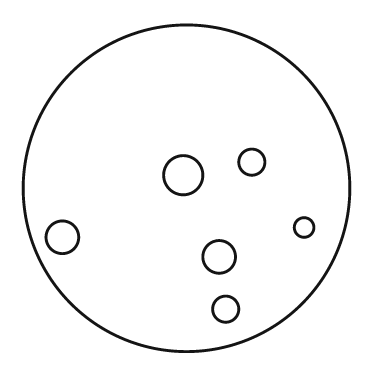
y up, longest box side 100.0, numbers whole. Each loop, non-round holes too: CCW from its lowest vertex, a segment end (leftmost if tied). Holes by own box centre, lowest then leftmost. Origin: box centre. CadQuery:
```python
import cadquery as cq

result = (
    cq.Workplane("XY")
    .moveTo(0.0, 0.0)
    .circle(50.0)
    .moveTo(12.0, -37.0)
    .circle(4.0)
    .moveTo(10.0, -21.0)
    .circle(5.0)
    .moveTo(-38.0, -15.0)
    .circle(5.0)
    .moveTo(36.0, -12.0)
    .circle(3.0)
    .moveTo(-1.0, 4.0)
    .circle(6.0)
    .moveTo(20.0, 8.0)
    .circle(4.0)
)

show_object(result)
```